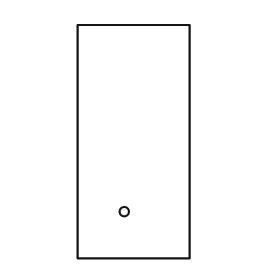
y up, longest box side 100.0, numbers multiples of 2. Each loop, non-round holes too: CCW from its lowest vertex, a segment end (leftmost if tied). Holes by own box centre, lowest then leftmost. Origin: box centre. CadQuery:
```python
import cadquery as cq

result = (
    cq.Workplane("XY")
    .moveTo(-24.0, -50.0)
    .lineTo(24.0, -50.0)
    .lineTo(24.0, 50.0)
    .lineTo(-24.0, 50.0)
    .close()
    .moveTo(-4.0, -30.0)
    .circle(2.0)
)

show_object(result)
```